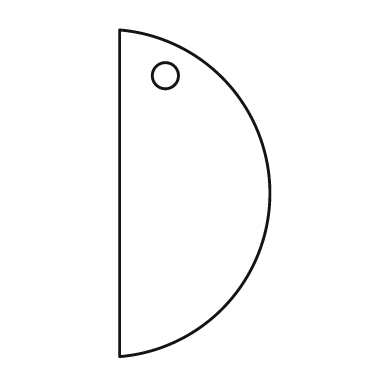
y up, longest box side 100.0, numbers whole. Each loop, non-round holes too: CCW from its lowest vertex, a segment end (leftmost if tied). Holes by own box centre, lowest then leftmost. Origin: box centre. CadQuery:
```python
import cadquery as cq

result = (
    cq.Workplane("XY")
    .moveTo(-23.0, -50.0)
    .threePointArc((23.0, 0.0), (-23.0, 50.0))
    .close()
    .moveTo(-9.0, 36.0)
    .circle(4.0)
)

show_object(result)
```